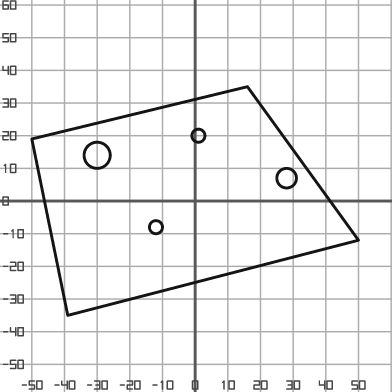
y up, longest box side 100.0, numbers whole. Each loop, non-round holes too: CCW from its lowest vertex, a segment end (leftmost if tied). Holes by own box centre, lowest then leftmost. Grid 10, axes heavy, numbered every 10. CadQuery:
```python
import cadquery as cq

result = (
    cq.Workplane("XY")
    .moveTo(-39.0, -35.0)
    .lineTo(50.0, -12.0)
    .lineTo(16.0, 35.0)
    .lineTo(-50.0, 19.0)
    .close()
    .moveTo(-12.0, -8.0)
    .circle(2.0)
    .moveTo(28.0, 7.0)
    .circle(3.0)
    .moveTo(-30.0, 14.0)
    .circle(4.0)
    .moveTo(1.0, 20.0)
    .circle(2.0)
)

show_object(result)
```